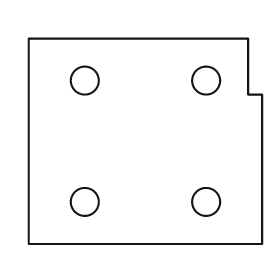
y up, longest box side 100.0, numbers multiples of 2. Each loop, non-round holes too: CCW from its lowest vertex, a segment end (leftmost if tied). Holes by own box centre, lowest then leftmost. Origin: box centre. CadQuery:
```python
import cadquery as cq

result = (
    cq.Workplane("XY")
    .moveTo(-50.0, -44.0)
    .lineTo(50.0, -44.0)
    .lineTo(50.0, 20.0)
    .lineTo(44.0, 20.0)
    .lineTo(44.0, 44.0)
    .lineTo(-50.0, 44.0)
    .close()
    .moveTo(-26.0, -26.0)
    .circle(6.0)
    .moveTo(26.0, -26.0)
    .circle(6.0)
    .moveTo(-26.0, 26.0)
    .circle(6.0)
    .moveTo(26.0, 26.0)
    .circle(6.0)
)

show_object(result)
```